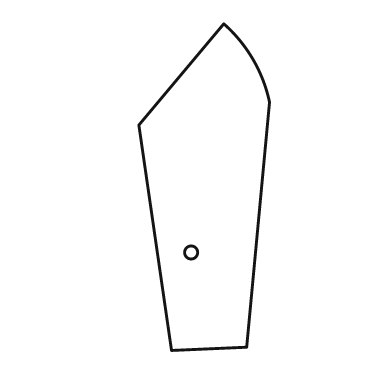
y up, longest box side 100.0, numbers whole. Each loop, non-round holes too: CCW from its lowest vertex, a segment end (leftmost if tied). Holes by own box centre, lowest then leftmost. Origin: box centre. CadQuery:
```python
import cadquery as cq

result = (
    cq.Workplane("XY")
    .moveTo(-10.0, -50.0)
    .lineTo(13.0, -49.0)
    .lineTo(20.0, 26.0)
    .threePointArc((15.0, 39.0), (6.0, 50.0))
    .lineTo(-20.0, 19.0)
    .close()
    .moveTo(-4.0, -20.0)
    .circle(2.0)
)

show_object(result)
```